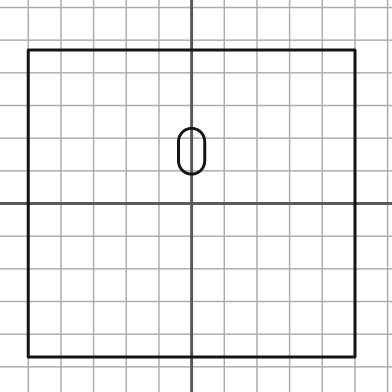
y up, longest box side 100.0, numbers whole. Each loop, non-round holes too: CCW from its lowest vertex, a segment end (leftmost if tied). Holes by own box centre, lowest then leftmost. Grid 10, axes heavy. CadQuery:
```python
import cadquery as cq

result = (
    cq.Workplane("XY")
    .moveTo(-50.0, -47.0)
    .lineTo(50.0, -47.0)
    .lineTo(50.0, 47.0)
    .lineTo(-50.0, 47.0)
    .close()
    .moveTo(-4.0, 13.0)
    .threePointArc((0.0, 9.0), (4.0, 13.0))
    .lineTo(4.0, 19.0)
    .threePointArc((0.0, 23.0), (-4.0, 19.0))
    .close()
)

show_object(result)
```